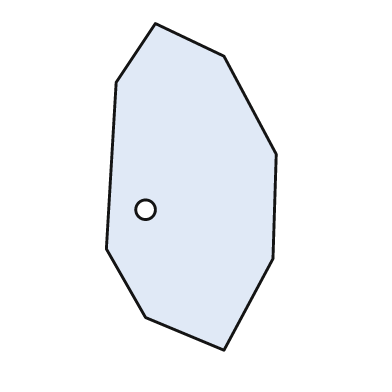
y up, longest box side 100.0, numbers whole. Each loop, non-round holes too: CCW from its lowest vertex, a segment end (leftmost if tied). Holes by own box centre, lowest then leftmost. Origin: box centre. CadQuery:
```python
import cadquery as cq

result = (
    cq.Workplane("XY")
    .moveTo(10.0, -50.0)
    .lineTo(25.0, -22.0)
    .lineTo(26.0, 10.0)
    .lineTo(10.0, 40.0)
    .lineTo(-11.0, 50.0)
    .lineTo(-23.0, 32.0)
    .lineTo(-26.0, -19.0)
    .lineTo(-14.0, -40.0)
    .close()
    .moveTo(-14.0, -7.0)
    .circle(3.0)
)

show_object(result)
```